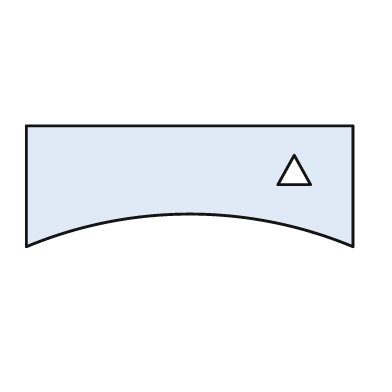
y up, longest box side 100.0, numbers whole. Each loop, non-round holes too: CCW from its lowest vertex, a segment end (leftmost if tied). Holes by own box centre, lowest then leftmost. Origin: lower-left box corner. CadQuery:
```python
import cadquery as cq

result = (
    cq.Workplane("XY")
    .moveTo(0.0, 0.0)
    .threePointArc((50.0, 10.0), (100.0, 0.0))
    .lineTo(100.0, 37.0)
    .lineTo(0.0, 37.0)
    .close()
    .moveTo(77.0, 19.0)
    .lineTo(87.0, 19.0)
    .lineTo(82.0, 28.0)
    .close()
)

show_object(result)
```